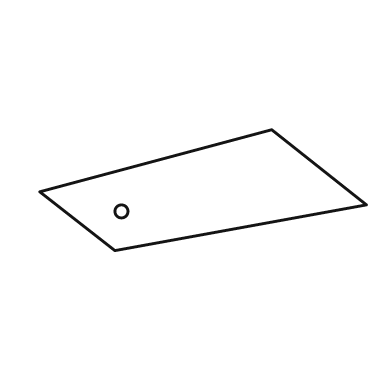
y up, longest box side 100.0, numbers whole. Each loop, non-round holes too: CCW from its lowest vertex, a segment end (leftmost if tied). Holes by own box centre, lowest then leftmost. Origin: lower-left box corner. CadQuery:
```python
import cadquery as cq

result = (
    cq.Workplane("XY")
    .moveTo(23.0, 0.0)
    .lineTo(100.0, 14.0)
    .lineTo(71.0, 37.0)
    .lineTo(0.0, 18.0)
    .close()
    .moveTo(25.0, 12.0)
    .circle(2.0)
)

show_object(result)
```